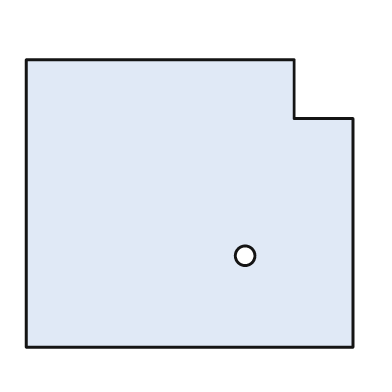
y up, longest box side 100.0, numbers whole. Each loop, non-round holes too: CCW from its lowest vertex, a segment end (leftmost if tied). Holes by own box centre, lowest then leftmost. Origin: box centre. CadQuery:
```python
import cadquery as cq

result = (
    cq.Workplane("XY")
    .moveTo(-50.0, -44.0)
    .lineTo(50.0, -44.0)
    .lineTo(50.0, 26.0)
    .lineTo(32.0, 26.0)
    .lineTo(32.0, 44.0)
    .lineTo(-50.0, 44.0)
    .close()
    .moveTo(17.0, -16.0)
    .circle(3.0)
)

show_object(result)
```